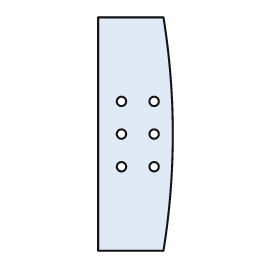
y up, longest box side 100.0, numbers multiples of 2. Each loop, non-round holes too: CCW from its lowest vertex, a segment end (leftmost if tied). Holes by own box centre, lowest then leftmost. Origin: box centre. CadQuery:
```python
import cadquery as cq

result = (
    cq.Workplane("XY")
    .moveTo(-16.0, -50.0)
    .lineTo(12.0, -50.0)
    .threePointArc((16.0, 0.0), (12.0, 50.0))
    .lineTo(-16.0, 50.0)
    .close()
    .moveTo(-6.0, -14.0)
    .circle(2.0)
    .moveTo(8.0, -14.0)
    .circle(2.0)
    .moveTo(-6.0, 0.0)
    .circle(2.0)
    .moveTo(8.0, 0.0)
    .circle(2.0)
    .moveTo(-6.0, 14.0)
    .circle(2.0)
    .moveTo(8.0, 14.0)
    .circle(2.0)
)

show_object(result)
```